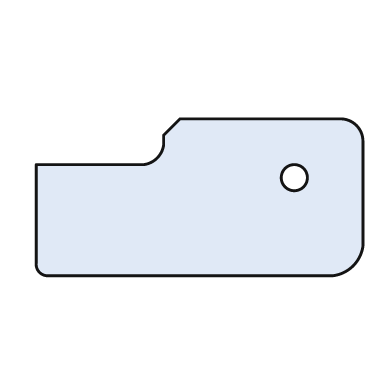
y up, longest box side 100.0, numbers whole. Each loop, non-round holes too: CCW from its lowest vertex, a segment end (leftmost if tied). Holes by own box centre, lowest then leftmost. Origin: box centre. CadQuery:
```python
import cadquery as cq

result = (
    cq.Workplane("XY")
    .moveTo(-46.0, -24.0)
    .lineTo(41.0, -24.0)
    .threePointArc((47.0, -21.0), (50.0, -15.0))
    .lineTo(50.0, 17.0)
    .threePointArc((48.0, 22.0), (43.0, 24.0))
    .lineTo(-6.0, 24.0)
    .lineTo(-11.0, 19.0)
    .lineTo(-11.0, 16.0)
    .threePointArc((-13.0, 12.0), (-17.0, 10.0))
    .lineTo(-50.0, 10.0)
    .lineTo(-50.0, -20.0)
    .threePointArc((-49.0, -23.0), (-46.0, -24.0))
    .close()
    .moveTo(29.0, 6.0)
    .circle(4.0)
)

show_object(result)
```